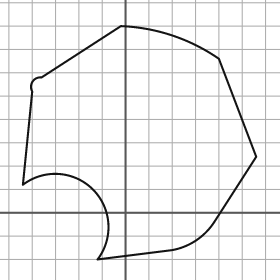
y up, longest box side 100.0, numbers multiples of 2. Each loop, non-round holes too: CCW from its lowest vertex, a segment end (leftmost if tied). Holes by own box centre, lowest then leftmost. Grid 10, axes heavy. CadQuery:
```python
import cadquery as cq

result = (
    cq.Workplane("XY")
    .moveTo(-12.0, -20.0)
    .lineTo(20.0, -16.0)
    .threePointArc((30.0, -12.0), (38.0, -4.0))
    .lineTo(56.0, 24.0)
    .lineTo(40.0, 66.0)
    .threePointArc((20.0, 76.0), (-2.0, 80.0))
    .lineTo(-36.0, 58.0)
    .threePointArc((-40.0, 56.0), (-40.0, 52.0))
    .lineTo(-44.0, 12.0)
    .threePointArc((-14.0, 10.0), (-12.0, -20.0))
    .close()
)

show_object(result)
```